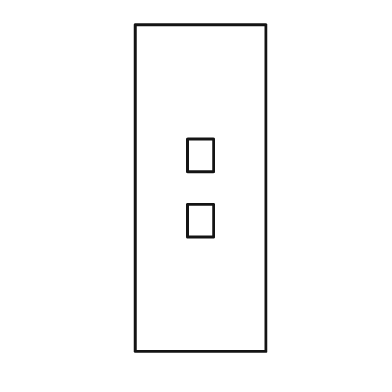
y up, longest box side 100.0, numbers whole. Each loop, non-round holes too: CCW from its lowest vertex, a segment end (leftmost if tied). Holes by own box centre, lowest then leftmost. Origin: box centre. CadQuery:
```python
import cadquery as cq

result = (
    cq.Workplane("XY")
    .moveTo(-20.0, -50.0)
    .lineTo(20.0, -50.0)
    .lineTo(20.0, 50.0)
    .lineTo(-20.0, 50.0)
    .close()
    .moveTo(-4.0, -15.0)
    .lineTo(4.0, -15.0)
    .lineTo(4.0, -5.0)
    .lineTo(-4.0, -5.0)
    .close()
    .moveTo(-4.0, 5.0)
    .lineTo(4.0, 5.0)
    .lineTo(4.0, 15.0)
    .lineTo(-4.0, 15.0)
    .close()
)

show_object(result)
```